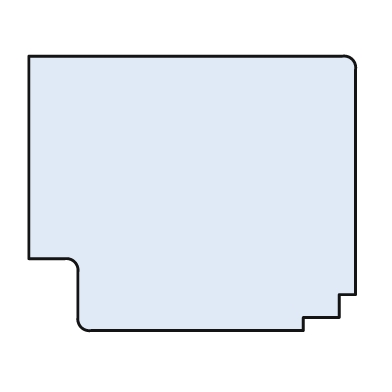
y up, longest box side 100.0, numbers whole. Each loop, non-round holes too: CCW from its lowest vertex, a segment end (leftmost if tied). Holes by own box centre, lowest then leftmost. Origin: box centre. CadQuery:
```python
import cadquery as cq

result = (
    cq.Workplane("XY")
    .moveTo(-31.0, -42.0)
    .lineTo(34.0, -42.0)
    .lineTo(34.0, -38.0)
    .lineTo(45.0, -38.0)
    .lineTo(45.0, -31.0)
    .lineTo(50.0, -31.0)
    .lineTo(50.0, 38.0)
    .threePointArc((49.0, 41.0), (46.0, 42.0))
    .lineTo(-50.0, 42.0)
    .lineTo(-50.0, -20.0)
    .lineTo(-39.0, -20.0)
    .threePointArc((-36.0, -21.0), (-35.0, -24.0))
    .lineTo(-35.0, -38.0)
    .threePointArc((-34.0, -41.0), (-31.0, -42.0))
    .close()
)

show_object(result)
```